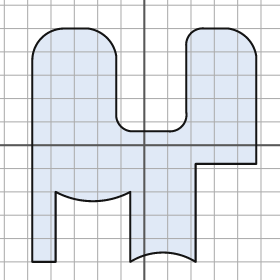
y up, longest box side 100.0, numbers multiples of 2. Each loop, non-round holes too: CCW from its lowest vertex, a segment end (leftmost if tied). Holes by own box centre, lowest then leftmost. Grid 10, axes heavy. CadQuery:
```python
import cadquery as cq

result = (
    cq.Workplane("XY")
    .moveTo(-48.0, -50.0)
    .lineTo(-38.0, -50.0)
    .lineTo(-38.0, -20.0)
    .threePointArc((-22.0, -24.0), (-6.0, -20.0))
    .lineTo(-6.0, -50.0)
    .threePointArc((8.0, -46.0), (22.0, -50.0))
    .lineTo(22.0, -8.0)
    .lineTo(48.0, -8.0)
    .lineTo(48.0, 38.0)
    .threePointArc((44.0, 46.0), (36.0, 50.0))
    .lineTo(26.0, 50.0)
    .threePointArc((20.0, 48.0), (18.0, 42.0))
    .lineTo(18.0, 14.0)
    .threePointArc((16.0, 8.0), (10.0, 6.0))
    .lineTo(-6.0, 6.0)
    .threePointArc((-10.0, 8.0), (-12.0, 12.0))
    .lineTo(-12.0, 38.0)
    .threePointArc((-16.0, 46.0), (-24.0, 50.0))
    .lineTo(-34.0, 50.0)
    .threePointArc((-44.0, 46.0), (-48.0, 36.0))
    .close()
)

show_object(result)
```